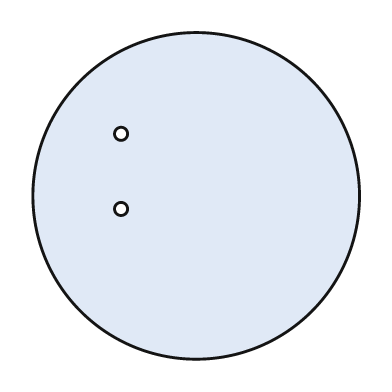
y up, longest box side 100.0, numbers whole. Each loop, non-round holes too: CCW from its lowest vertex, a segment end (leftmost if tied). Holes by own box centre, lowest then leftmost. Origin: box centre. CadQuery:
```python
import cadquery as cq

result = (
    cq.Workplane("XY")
    .moveTo(0.0, 0.0)
    .circle(50.0)
    .moveTo(-23.0, -4.0)
    .circle(2.0)
    .moveTo(-23.0, 19.0)
    .circle(2.0)
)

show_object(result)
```